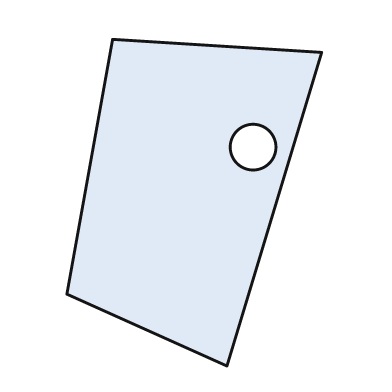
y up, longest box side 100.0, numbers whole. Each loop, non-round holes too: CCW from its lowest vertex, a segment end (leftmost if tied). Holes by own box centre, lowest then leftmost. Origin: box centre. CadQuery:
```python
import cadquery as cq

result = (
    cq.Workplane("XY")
    .moveTo(10.0, -50.0)
    .lineTo(39.0, 46.0)
    .lineTo(-25.0, 50.0)
    .lineTo(-39.0, -28.0)
    .close()
    .moveTo(18.0, 17.0)
    .circle(7.0)
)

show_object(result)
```